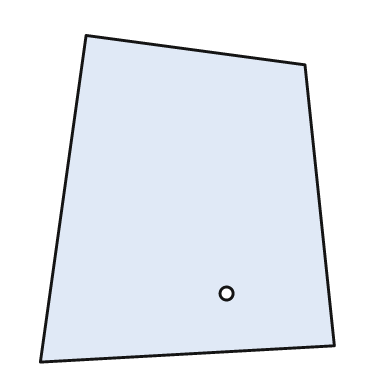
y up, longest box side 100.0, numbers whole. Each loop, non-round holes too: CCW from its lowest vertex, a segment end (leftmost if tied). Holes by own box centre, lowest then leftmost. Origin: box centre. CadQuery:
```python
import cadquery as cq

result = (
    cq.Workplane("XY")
    .moveTo(-45.0, -50.0)
    .lineTo(45.0, -45.0)
    .lineTo(36.0, 41.0)
    .lineTo(-31.0, 50.0)
    .close()
    .moveTo(12.0, -29.0)
    .circle(2.0)
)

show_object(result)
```